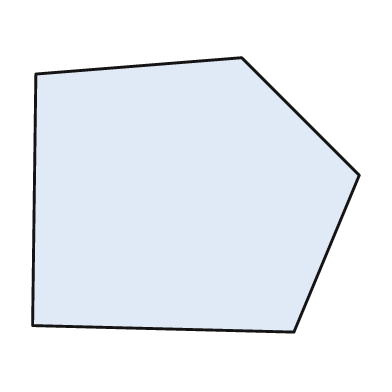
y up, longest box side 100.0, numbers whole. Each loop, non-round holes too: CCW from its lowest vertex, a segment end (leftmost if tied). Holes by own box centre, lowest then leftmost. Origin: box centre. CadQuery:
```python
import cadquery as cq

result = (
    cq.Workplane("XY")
    .moveTo(30.0, -42.0)
    .lineTo(50.0, 6.0)
    .lineTo(14.0, 42.0)
    .lineTo(-49.0, 37.0)
    .lineTo(-50.0, -40.0)
    .close()
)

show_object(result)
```